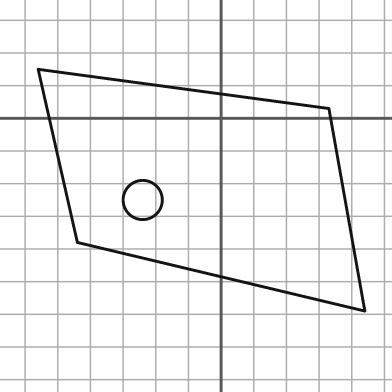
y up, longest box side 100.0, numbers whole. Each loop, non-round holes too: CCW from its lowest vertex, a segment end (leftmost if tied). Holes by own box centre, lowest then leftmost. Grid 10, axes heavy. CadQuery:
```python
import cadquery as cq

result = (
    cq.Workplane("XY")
    .moveTo(44.0, -59.0)
    .lineTo(33.0, 3.0)
    .lineTo(-56.0, 15.0)
    .lineTo(-44.0, -38.0)
    .close()
    .moveTo(-24.0, -25.0)
    .circle(6.0)
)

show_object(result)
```